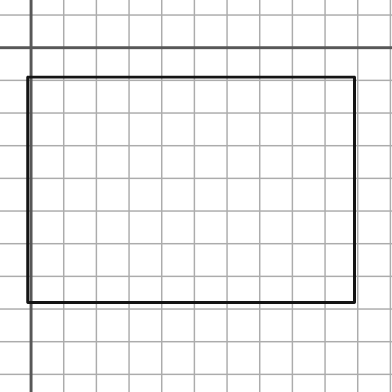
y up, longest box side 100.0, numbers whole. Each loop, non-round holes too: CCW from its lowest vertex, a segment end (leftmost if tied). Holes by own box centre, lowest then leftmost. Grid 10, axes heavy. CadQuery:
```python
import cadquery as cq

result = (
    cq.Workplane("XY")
    .moveTo(-1.0, -78.0)
    .lineTo(99.0, -78.0)
    .lineTo(99.0, -9.0)
    .lineTo(-1.0, -9.0)
    .close()
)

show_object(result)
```